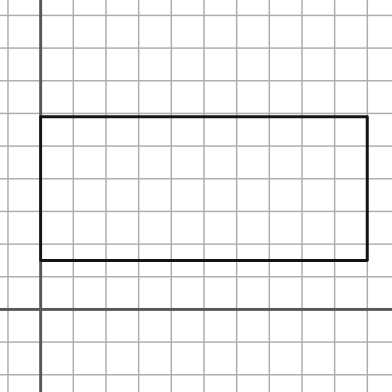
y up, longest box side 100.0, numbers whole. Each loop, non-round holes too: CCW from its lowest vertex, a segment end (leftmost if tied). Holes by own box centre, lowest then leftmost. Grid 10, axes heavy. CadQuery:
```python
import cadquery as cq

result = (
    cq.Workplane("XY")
    .moveTo(0.0, 15.0)
    .lineTo(100.0, 15.0)
    .lineTo(100.0, 59.0)
    .lineTo(0.0, 59.0)
    .close()
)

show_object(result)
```